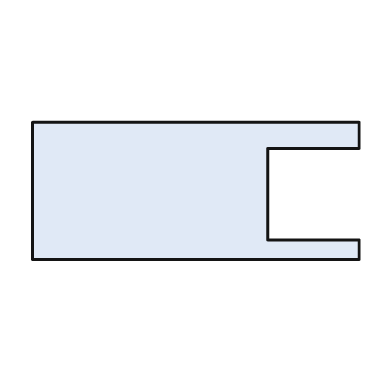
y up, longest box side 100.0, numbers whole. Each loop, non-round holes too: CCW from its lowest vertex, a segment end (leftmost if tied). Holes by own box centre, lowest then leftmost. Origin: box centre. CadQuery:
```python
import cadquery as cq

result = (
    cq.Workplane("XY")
    .moveTo(-50.0, -21.0)
    .lineTo(50.0, -21.0)
    .lineTo(50.0, -15.0)
    .lineTo(22.0, -15.0)
    .lineTo(22.0, 13.0)
    .lineTo(50.0, 13.0)
    .lineTo(50.0, 21.0)
    .lineTo(-50.0, 21.0)
    .close()
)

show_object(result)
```